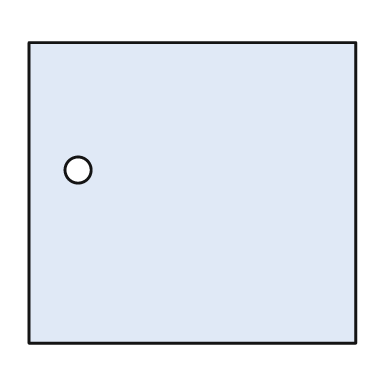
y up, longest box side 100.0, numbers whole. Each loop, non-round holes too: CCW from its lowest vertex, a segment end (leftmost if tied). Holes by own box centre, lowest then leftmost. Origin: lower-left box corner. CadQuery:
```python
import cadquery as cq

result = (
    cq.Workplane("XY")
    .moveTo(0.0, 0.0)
    .lineTo(100.0, 0.0)
    .lineTo(100.0, 92.0)
    .lineTo(0.0, 92.0)
    .close()
    .moveTo(15.0, 53.0)
    .circle(4.0)
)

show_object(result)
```